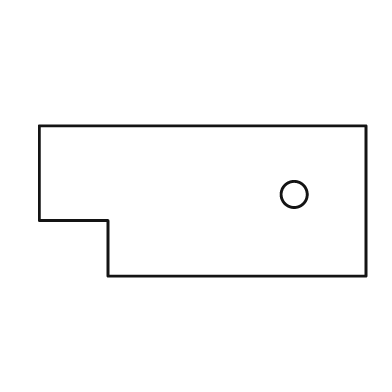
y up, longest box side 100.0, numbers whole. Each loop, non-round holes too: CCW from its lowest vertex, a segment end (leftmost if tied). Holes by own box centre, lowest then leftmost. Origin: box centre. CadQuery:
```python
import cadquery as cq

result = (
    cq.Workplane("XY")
    .moveTo(-29.0, -23.0)
    .lineTo(50.0, -23.0)
    .lineTo(50.0, 23.0)
    .lineTo(-50.0, 23.0)
    .lineTo(-50.0, -6.0)
    .lineTo(-29.0, -6.0)
    .close()
    .moveTo(28.0, 2.0)
    .circle(4.0)
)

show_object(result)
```